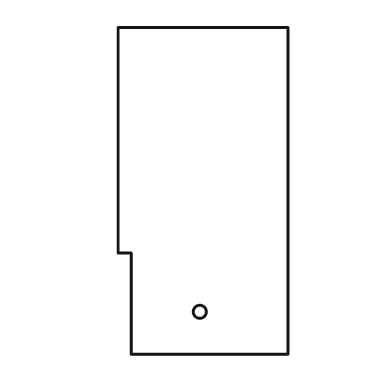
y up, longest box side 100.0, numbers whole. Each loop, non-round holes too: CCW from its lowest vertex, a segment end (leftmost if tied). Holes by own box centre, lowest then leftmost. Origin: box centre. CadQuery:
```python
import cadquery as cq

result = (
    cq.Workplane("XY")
    .moveTo(-22.0, -50.0)
    .lineTo(26.0, -50.0)
    .lineTo(26.0, 50.0)
    .lineTo(-26.0, 50.0)
    .lineTo(-26.0, -19.0)
    .lineTo(-22.0, -19.0)
    .close()
    .moveTo(-1.0, -37.0)
    .circle(2.0)
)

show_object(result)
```